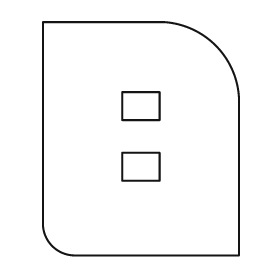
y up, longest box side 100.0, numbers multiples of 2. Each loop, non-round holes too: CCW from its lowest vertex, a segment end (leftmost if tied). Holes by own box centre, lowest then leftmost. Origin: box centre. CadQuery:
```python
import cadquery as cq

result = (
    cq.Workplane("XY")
    .moveTo(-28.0, -50.0)
    .lineTo(42.0, -50.0)
    .lineTo(42.0, 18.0)
    .threePointArc((32.0, 40.0), (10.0, 50.0))
    .lineTo(-42.0, 50.0)
    .lineTo(-42.0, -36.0)
    .threePointArc((-38.0, -46.0), (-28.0, -50.0))
    .close()
    .moveTo(-8.0, -18.0)
    .lineTo(8.0, -18.0)
    .lineTo(8.0, -6.0)
    .lineTo(-8.0, -6.0)
    .close()
    .moveTo(-8.0, 8.0)
    .lineTo(8.0, 8.0)
    .lineTo(8.0, 20.0)
    .lineTo(-8.0, 20.0)
    .close()
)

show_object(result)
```